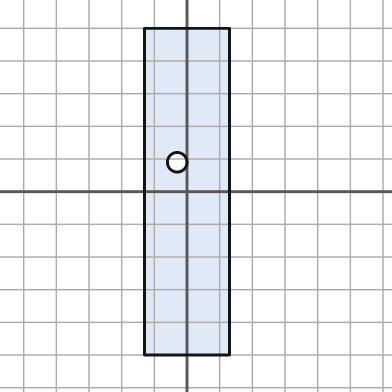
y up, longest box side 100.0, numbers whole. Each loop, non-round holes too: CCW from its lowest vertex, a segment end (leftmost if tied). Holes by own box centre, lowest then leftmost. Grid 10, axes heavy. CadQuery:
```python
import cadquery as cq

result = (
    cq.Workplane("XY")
    .moveTo(-13.0, -50.0)
    .lineTo(13.0, -50.0)
    .lineTo(13.0, 50.0)
    .lineTo(-13.0, 50.0)
    .close()
    .moveTo(-3.0, 9.0)
    .circle(3.0)
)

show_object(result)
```